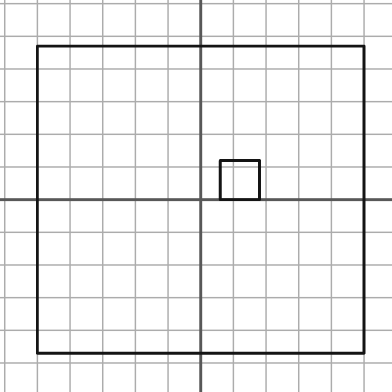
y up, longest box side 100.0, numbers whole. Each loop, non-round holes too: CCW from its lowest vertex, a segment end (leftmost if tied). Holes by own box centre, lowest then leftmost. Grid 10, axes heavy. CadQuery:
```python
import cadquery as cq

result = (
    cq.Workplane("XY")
    .moveTo(-50.0, -47.0)
    .lineTo(50.0, -47.0)
    .lineTo(50.0, 47.0)
    .lineTo(-50.0, 47.0)
    .close()
    .moveTo(6.0, 0.0)
    .lineTo(18.0, 0.0)
    .lineTo(18.0, 12.0)
    .lineTo(6.0, 12.0)
    .close()
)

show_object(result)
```